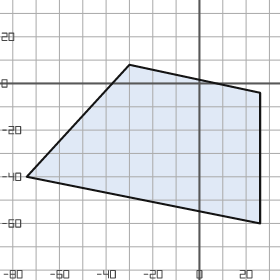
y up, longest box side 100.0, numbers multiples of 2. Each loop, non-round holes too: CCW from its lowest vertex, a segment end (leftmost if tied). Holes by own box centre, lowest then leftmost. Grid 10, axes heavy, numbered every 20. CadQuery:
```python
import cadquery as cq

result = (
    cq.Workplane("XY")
    .moveTo(26.0, -60.0)
    .lineTo(26.0, -4.0)
    .lineTo(-30.0, 8.0)
    .lineTo(-74.0, -40.0)
    .close()
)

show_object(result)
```